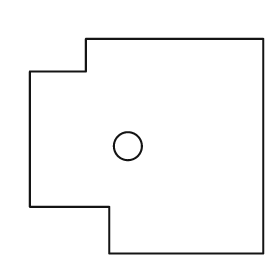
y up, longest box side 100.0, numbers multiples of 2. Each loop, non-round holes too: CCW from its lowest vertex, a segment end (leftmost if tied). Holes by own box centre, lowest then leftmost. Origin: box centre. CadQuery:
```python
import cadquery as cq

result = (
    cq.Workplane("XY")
    .moveTo(-16.0, -46.0)
    .lineTo(50.0, -46.0)
    .lineTo(50.0, 46.0)
    .lineTo(-26.0, 46.0)
    .lineTo(-26.0, 32.0)
    .lineTo(-50.0, 32.0)
    .lineTo(-50.0, -26.0)
    .lineTo(-16.0, -26.0)
    .close()
    .moveTo(-8.0, 0.0)
    .circle(6.0)
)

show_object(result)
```